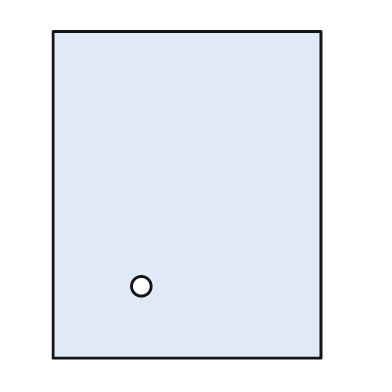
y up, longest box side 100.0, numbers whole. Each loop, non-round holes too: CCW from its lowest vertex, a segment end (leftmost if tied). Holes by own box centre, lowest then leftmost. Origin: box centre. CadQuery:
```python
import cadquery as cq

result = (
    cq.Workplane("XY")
    .moveTo(-41.0, -50.0)
    .lineTo(41.0, -50.0)
    .lineTo(41.0, 50.0)
    .lineTo(-41.0, 50.0)
    .close()
    .moveTo(-14.0, -28.0)
    .circle(3.0)
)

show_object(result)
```